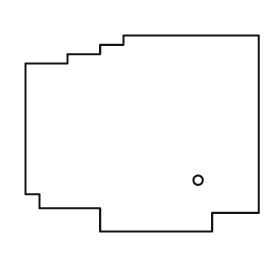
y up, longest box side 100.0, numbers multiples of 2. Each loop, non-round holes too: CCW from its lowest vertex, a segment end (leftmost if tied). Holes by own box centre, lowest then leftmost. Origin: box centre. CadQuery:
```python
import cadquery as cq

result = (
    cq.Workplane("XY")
    .moveTo(-18.0, -42.0)
    .lineTo(30.0, -42.0)
    .lineTo(30.0, -34.0)
    .lineTo(50.0, -34.0)
    .lineTo(50.0, 42.0)
    .lineTo(-8.0, 42.0)
    .lineTo(-8.0, 38.0)
    .lineTo(-18.0, 38.0)
    .lineTo(-18.0, 34.0)
    .lineTo(-32.0, 34.0)
    .lineTo(-32.0, 30.0)
    .lineTo(-50.0, 30.0)
    .lineTo(-50.0, -26.0)
    .lineTo(-44.0, -26.0)
    .lineTo(-44.0, -32.0)
    .lineTo(-18.0, -32.0)
    .close()
    .moveTo(24.0, -20.0)
    .circle(2.0)
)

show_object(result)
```